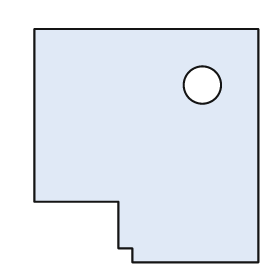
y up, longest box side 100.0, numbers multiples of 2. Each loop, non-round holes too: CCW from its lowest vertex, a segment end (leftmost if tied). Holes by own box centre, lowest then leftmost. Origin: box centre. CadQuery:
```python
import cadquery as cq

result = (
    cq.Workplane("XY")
    .moveTo(-6.0, -50.0)
    .lineTo(48.0, -50.0)
    .lineTo(48.0, 50.0)
    .lineTo(-48.0, 50.0)
    .lineTo(-48.0, -24.0)
    .lineTo(-12.0, -24.0)
    .lineTo(-12.0, -44.0)
    .lineTo(-6.0, -44.0)
    .close()
    .moveTo(24.0, 26.0)
    .circle(8.0)
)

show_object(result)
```